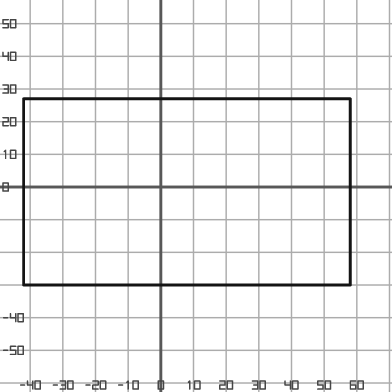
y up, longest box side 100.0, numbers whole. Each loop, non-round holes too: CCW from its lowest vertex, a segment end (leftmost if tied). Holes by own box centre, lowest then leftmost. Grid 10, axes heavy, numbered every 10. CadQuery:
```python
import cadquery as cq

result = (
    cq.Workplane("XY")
    .moveTo(-42.0, -30.0)
    .lineTo(58.0, -30.0)
    .lineTo(58.0, 27.0)
    .lineTo(-42.0, 27.0)
    .close()
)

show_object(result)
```